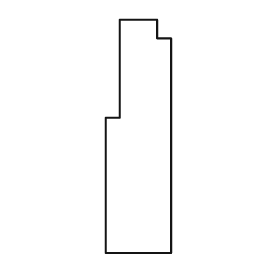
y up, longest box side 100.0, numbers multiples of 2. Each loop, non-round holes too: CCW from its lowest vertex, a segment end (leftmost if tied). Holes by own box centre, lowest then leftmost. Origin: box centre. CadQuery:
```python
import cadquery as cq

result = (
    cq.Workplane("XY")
    .moveTo(-14.0, -50.0)
    .lineTo(14.0, -50.0)
    .lineTo(14.0, 42.0)
    .lineTo(8.0, 42.0)
    .lineTo(8.0, 50.0)
    .lineTo(-8.0, 50.0)
    .lineTo(-8.0, 8.0)
    .lineTo(-14.0, 8.0)
    .close()
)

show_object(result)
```